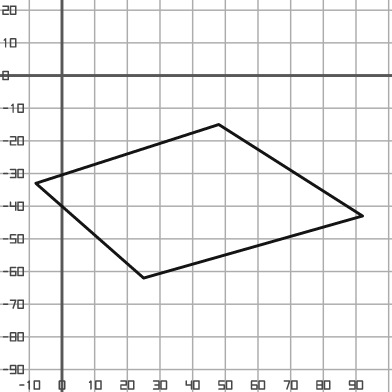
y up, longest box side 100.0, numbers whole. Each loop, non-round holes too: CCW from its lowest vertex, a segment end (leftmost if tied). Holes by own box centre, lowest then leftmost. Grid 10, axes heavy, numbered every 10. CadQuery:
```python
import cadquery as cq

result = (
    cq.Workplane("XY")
    .moveTo(25.0, -62.0)
    .lineTo(92.0, -43.0)
    .lineTo(48.0, -15.0)
    .lineTo(-8.0, -33.0)
    .close()
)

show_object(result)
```